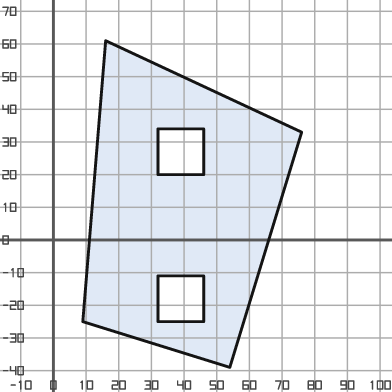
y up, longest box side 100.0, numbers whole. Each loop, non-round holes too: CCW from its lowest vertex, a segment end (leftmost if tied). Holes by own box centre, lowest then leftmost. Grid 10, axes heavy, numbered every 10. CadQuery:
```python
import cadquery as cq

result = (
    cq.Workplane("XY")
    .moveTo(54.0, -39.0)
    .lineTo(76.0, 33.0)
    .lineTo(16.0, 61.0)
    .lineTo(9.0, -25.0)
    .close()
    .moveTo(32.0, -25.0)
    .lineTo(46.0, -25.0)
    .lineTo(46.0, -11.0)
    .lineTo(32.0, -11.0)
    .close()
    .moveTo(32.0, 20.0)
    .lineTo(46.0, 20.0)
    .lineTo(46.0, 34.0)
    .lineTo(32.0, 34.0)
    .close()
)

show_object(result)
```